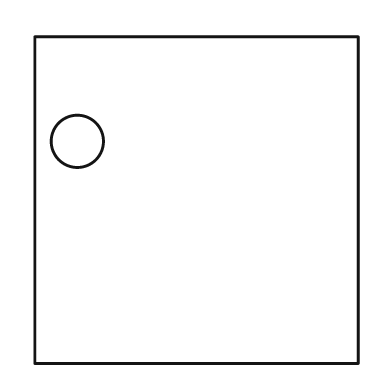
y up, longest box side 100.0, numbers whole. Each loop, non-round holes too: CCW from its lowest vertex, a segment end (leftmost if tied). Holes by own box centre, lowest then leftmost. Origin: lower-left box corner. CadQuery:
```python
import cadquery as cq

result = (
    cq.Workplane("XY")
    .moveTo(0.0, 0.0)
    .lineTo(99.0, 0.0)
    .lineTo(99.0, 100.0)
    .lineTo(0.0, 100.0)
    .close()
    .moveTo(13.0, 68.0)
    .circle(8.0)
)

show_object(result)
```